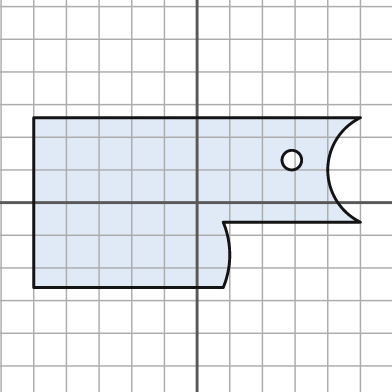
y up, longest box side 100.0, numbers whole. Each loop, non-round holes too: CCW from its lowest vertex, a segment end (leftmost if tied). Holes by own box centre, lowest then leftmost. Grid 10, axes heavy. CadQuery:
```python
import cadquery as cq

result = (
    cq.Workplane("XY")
    .moveTo(-50.0, -26.0)
    .lineTo(8.0, -26.0)
    .threePointArc((10.0, -16.0), (8.0, -6.0))
    .lineTo(50.0, -6.0)
    .threePointArc((40.0, 10.0), (50.0, 26.0))
    .lineTo(-50.0, 26.0)
    .close()
    .moveTo(29.0, 13.0)
    .circle(3.0)
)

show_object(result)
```